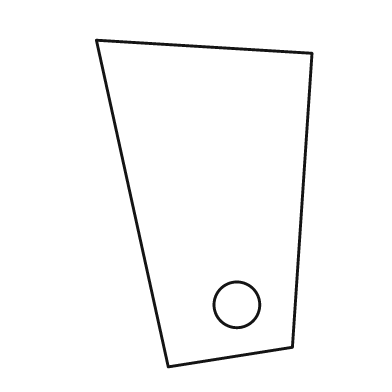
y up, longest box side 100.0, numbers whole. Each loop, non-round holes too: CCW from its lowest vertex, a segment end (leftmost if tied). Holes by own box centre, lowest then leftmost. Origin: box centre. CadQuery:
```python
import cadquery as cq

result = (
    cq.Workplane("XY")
    .moveTo(-11.0, -50.0)
    .lineTo(27.0, -44.0)
    .lineTo(33.0, 46.0)
    .lineTo(-33.0, 50.0)
    .close()
    .moveTo(10.0, -31.0)
    .circle(7.0)
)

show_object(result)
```